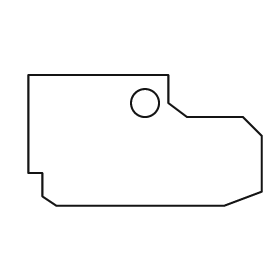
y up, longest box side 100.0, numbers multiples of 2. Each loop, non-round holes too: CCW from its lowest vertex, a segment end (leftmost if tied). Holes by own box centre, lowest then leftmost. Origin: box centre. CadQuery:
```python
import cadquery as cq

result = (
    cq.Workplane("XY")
    .moveTo(-38.0, -28.0)
    .lineTo(34.0, -28.0)
    .lineTo(50.0, -22.0)
    .lineTo(50.0, 2.0)
    .lineTo(42.0, 10.0)
    .lineTo(18.0, 10.0)
    .lineTo(10.0, 16.0)
    .lineTo(10.0, 28.0)
    .lineTo(-50.0, 28.0)
    .lineTo(-50.0, -14.0)
    .lineTo(-44.0, -14.0)
    .lineTo(-44.0, -24.0)
    .close()
    .moveTo(0.0, 16.0)
    .circle(6.0)
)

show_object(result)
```